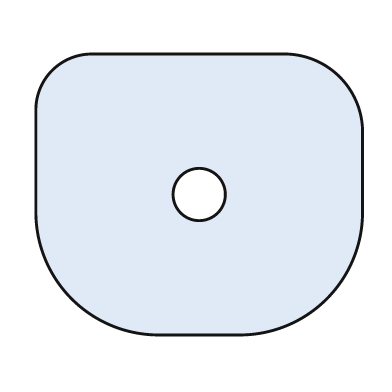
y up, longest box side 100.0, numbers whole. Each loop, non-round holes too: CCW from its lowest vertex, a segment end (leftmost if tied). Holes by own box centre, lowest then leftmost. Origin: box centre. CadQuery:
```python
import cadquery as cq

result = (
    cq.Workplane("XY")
    .moveTo(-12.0, -43.0)
    .lineTo(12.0, -43.0)
    .threePointArc((39.0, -32.0), (50.0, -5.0))
    .lineTo(50.0, 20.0)
    .threePointArc((43.0, 36.0), (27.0, 43.0))
    .lineTo(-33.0, 43.0)
    .threePointArc((-45.0, 38.0), (-50.0, 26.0))
    .lineTo(-50.0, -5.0)
    .threePointArc((-39.0, -32.0), (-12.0, -43.0))
    .close()
    .moveTo(0.0, 0.0)
    .circle(8.0)
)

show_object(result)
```